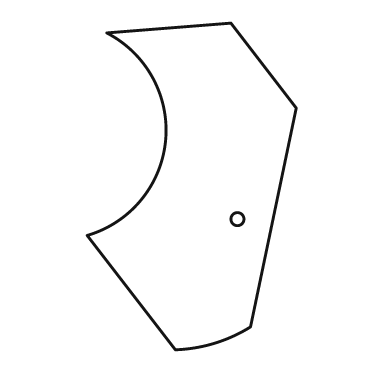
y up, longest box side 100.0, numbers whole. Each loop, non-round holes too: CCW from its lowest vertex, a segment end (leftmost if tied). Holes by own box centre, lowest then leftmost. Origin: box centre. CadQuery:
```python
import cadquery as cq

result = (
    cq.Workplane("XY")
    .moveTo(-5.0, -50.0)
    .threePointArc((7.0, -48.0), (18.0, -43.0))
    .lineTo(32.0, 24.0)
    .lineTo(12.0, 50.0)
    .lineTo(-26.0, 47.0)
    .threePointArc((-8.0, 14.0), (-32.0, -15.0))
    .close()
    .moveTo(14.0, -10.0)
    .circle(2.0)
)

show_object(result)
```